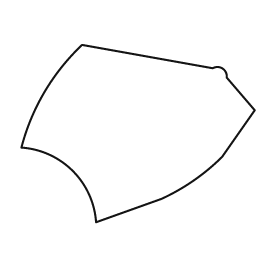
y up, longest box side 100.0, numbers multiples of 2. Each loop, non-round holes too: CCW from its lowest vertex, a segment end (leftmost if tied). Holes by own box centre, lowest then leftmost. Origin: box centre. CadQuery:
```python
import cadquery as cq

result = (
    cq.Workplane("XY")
    .moveTo(-18.0, -38.0)
    .lineTo(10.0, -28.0)
    .threePointArc((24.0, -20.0), (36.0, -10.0))
    .lineTo(50.0, 10.0)
    .lineTo(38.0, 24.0)
    .threePointArc((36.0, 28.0), (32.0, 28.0))
    .lineTo(-24.0, 38.0)
    .threePointArc((-40.0, 18.0), (-50.0, -6.0))
    .threePointArc((-28.0, -16.0), (-18.0, -38.0))
    .close()
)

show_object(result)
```